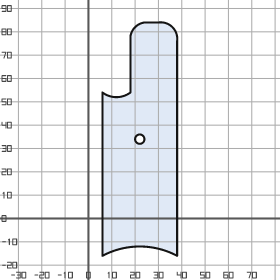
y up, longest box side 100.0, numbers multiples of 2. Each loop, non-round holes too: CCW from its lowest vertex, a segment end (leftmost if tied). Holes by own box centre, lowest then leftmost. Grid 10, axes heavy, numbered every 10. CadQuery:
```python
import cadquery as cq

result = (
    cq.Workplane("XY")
    .moveTo(6.0, -16.0)
    .threePointArc((22.0, -12.0), (38.0, -16.0))
    .lineTo(38.0, 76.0)
    .threePointArc((36.0, 82.0), (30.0, 84.0))
    .lineTo(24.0, 84.0)
    .threePointArc((20.0, 82.0), (18.0, 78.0))
    .lineTo(18.0, 54.0)
    .threePointArc((12.0, 52.0), (6.0, 54.0))
    .close()
    .moveTo(22.0, 34.0)
    .circle(2.0)
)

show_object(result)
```